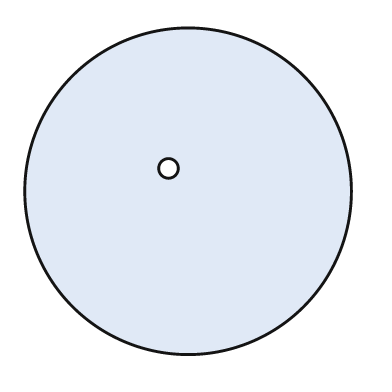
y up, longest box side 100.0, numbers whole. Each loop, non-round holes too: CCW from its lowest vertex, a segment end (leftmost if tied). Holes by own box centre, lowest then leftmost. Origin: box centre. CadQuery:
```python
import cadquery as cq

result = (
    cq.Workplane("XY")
    .moveTo(0.0, 0.0)
    .circle(50.0)
    .moveTo(-6.0, 7.0)
    .circle(3.0)
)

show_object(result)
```